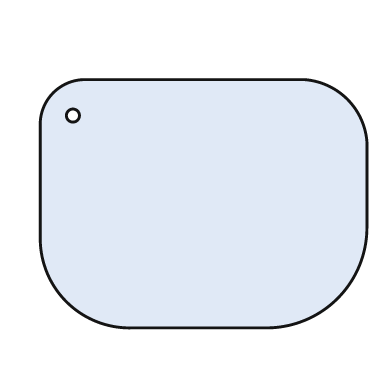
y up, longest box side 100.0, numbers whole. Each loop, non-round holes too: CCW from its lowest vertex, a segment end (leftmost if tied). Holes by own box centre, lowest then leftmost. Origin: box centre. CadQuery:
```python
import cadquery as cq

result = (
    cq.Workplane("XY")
    .moveTo(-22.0, -38.0)
    .lineTo(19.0, -38.0)
    .threePointArc((41.0, -29.0), (50.0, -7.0))
    .lineTo(50.0, 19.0)
    .threePointArc((44.0, 32.0), (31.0, 38.0))
    .lineTo(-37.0, 38.0)
    .threePointArc((-46.0, 34.0), (-50.0, 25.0))
    .lineTo(-50.0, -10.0)
    .threePointArc((-42.0, -30.0), (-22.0, -38.0))
    .close()
    .moveTo(-40.0, 27.0)
    .circle(2.0)
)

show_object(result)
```